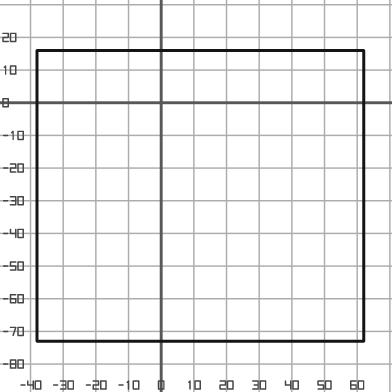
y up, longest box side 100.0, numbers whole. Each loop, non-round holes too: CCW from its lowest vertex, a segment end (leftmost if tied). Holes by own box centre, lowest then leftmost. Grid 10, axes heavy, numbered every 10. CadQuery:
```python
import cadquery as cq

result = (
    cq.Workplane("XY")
    .moveTo(-38.0, -73.0)
    .lineTo(62.0, -73.0)
    .lineTo(62.0, 16.0)
    .lineTo(-38.0, 16.0)
    .close()
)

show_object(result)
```